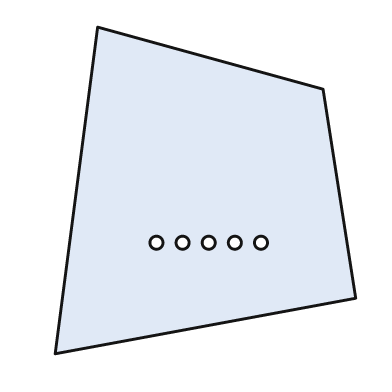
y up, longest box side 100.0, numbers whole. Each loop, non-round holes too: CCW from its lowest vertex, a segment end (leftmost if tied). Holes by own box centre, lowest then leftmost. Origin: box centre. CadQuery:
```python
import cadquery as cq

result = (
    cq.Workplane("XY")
    .moveTo(-46.0, -50.0)
    .lineTo(46.0, -33.0)
    .lineTo(36.0, 31.0)
    .lineTo(-33.0, 50.0)
    .close()
    .moveTo(-15.0, -16.0)
    .circle(2.0)
    .moveTo(-7.0, -16.0)
    .circle(2.0)
    .moveTo(1.0, -16.0)
    .circle(2.0)
    .moveTo(9.0, -16.0)
    .circle(2.0)
    .moveTo(17.0, -16.0)
    .circle(2.0)
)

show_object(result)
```